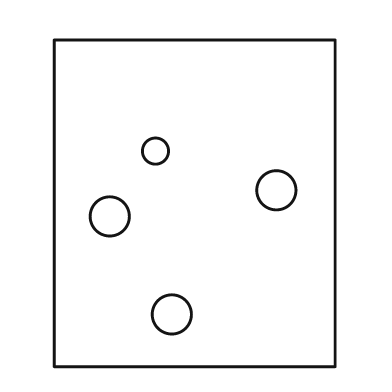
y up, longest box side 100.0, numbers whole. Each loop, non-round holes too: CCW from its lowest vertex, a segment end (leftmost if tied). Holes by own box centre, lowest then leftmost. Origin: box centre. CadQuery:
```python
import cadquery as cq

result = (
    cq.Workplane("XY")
    .moveTo(-43.0, -50.0)
    .lineTo(43.0, -50.0)
    .lineTo(43.0, 50.0)
    .lineTo(-43.0, 50.0)
    .close()
    .moveTo(-7.0, -34.0)
    .circle(6.0)
    .moveTo(-26.0, -4.0)
    .circle(6.0)
    .moveTo(25.0, 4.0)
    .circle(6.0)
    .moveTo(-12.0, 16.0)
    .circle(4.0)
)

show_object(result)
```